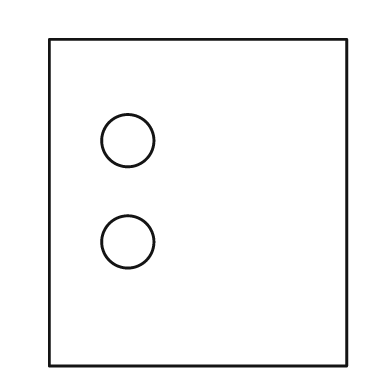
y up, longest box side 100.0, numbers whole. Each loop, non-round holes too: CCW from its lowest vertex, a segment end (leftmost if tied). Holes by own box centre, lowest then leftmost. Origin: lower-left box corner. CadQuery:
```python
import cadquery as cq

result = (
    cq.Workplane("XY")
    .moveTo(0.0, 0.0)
    .lineTo(91.0, 0.0)
    .lineTo(91.0, 100.0)
    .lineTo(0.0, 100.0)
    .close()
    .moveTo(24.0, 38.0)
    .circle(8.0)
    .moveTo(24.0, 69.0)
    .circle(8.0)
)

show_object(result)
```